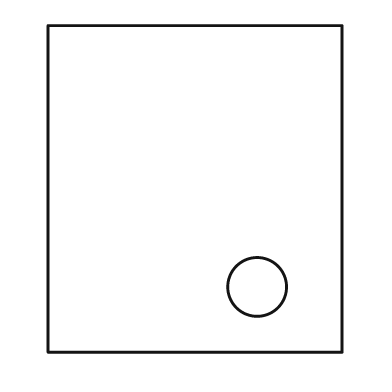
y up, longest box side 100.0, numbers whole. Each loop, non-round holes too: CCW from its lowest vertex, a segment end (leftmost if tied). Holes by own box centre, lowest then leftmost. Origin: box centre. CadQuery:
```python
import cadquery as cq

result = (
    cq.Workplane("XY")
    .moveTo(-45.0, -50.0)
    .lineTo(45.0, -50.0)
    .lineTo(45.0, 50.0)
    .lineTo(-45.0, 50.0)
    .close()
    .moveTo(19.0, -30.0)
    .circle(9.0)
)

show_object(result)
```